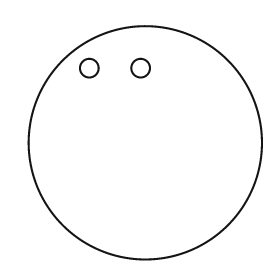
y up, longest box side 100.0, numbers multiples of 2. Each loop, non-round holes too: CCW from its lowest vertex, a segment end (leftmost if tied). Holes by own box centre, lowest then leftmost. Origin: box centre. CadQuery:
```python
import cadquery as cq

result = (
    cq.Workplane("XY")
    .moveTo(0.0, 0.0)
    .circle(50.0)
    .moveTo(-24.0, 32.0)
    .circle(4.0)
    .moveTo(-2.0, 32.0)
    .circle(4.0)
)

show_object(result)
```